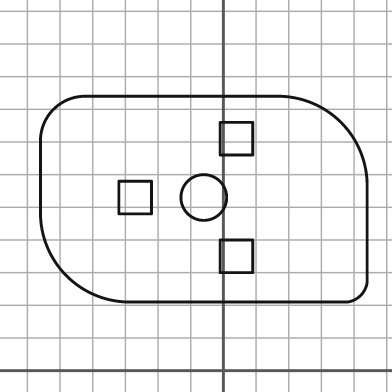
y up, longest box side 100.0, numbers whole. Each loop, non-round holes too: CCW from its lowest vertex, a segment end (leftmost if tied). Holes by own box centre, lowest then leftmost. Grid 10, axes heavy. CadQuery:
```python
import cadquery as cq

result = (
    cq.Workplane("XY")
    .moveTo(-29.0, 21.0)
    .lineTo(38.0, 21.0)
    .threePointArc((42.0, 23.0), (44.0, 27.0))
    .lineTo(44.0, 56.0)
    .threePointArc((36.0, 76.0), (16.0, 84.0))
    .lineTo(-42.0, 84.0)
    .threePointArc((-52.0, 80.0), (-56.0, 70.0))
    .lineTo(-56.0, 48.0)
    .threePointArc((-48.0, 29.0), (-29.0, 21.0))
    .close()
    .moveTo(-1.0, 30.0)
    .lineTo(9.0, 30.0)
    .lineTo(9.0, 40.0)
    .lineTo(-1.0, 40.0)
    .close()
    .moveTo(-32.0, 48.0)
    .lineTo(-22.0, 48.0)
    .lineTo(-22.0, 58.0)
    .lineTo(-32.0, 58.0)
    .close()
    .moveTo(-6.0, 53.0)
    .circle(7.0)
    .moveTo(-1.0, 66.0)
    .lineTo(9.0, 66.0)
    .lineTo(9.0, 76.0)
    .lineTo(-1.0, 76.0)
    .close()
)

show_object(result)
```